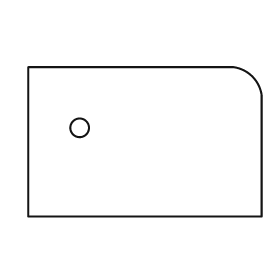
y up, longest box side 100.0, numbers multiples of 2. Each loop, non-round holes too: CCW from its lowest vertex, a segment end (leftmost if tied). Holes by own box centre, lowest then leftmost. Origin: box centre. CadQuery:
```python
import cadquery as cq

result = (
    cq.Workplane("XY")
    .moveTo(-50.0, -32.0)
    .lineTo(50.0, -32.0)
    .lineTo(50.0, 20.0)
    .threePointArc((46.0, 28.0), (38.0, 32.0))
    .lineTo(-50.0, 32.0)
    .close()
    .moveTo(-28.0, 6.0)
    .circle(4.0)
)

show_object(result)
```